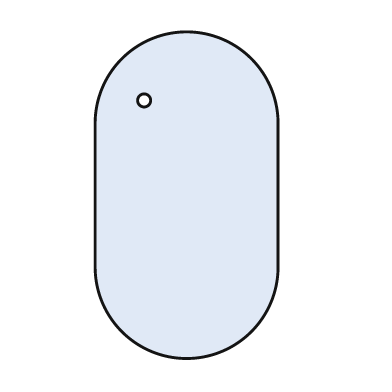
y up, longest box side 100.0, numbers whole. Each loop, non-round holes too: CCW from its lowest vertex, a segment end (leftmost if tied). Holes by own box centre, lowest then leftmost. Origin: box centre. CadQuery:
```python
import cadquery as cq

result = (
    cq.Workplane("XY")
    .moveTo(-28.0, -22.0)
    .threePointArc((0.0, -50.0), (28.0, -22.0))
    .lineTo(28.0, 22.0)
    .threePointArc((0.0, 50.0), (-28.0, 22.0))
    .close()
    .moveTo(-13.0, 29.0)
    .circle(2.0)
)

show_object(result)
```